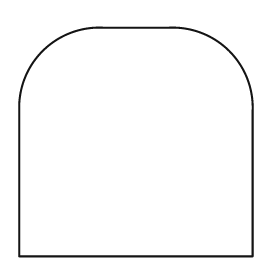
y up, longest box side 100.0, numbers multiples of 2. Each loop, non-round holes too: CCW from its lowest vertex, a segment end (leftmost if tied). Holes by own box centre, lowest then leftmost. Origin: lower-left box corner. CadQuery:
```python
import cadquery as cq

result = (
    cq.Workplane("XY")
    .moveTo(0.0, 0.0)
    .lineTo(100.0, 0.0)
    .lineTo(100.0, 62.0)
    .threePointArc((90.0, 88.0), (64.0, 98.0))
    .lineTo(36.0, 98.0)
    .threePointArc((10.0, 88.0), (0.0, 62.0))
    .close()
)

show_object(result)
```